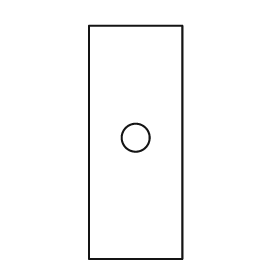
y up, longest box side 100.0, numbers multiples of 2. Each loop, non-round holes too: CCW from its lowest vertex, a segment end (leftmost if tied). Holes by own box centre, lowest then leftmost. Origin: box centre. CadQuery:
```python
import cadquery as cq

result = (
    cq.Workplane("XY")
    .moveTo(-20.0, -50.0)
    .lineTo(20.0, -50.0)
    .lineTo(20.0, 50.0)
    .lineTo(-20.0, 50.0)
    .close()
    .moveTo(0.0, 2.0)
    .circle(6.0)
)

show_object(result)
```